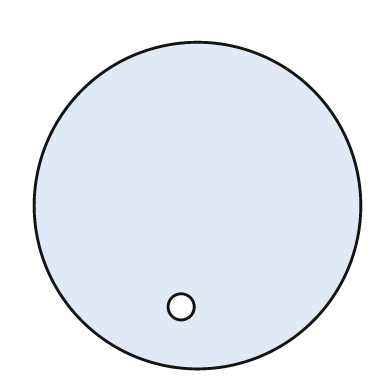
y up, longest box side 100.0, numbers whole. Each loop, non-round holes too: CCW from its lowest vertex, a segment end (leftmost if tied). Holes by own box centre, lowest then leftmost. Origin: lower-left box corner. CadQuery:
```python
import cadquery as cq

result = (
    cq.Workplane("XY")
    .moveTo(50.0, 50.0)
    .circle(50.0)
    .moveTo(45.0, 19.0)
    .circle(4.0)
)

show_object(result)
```